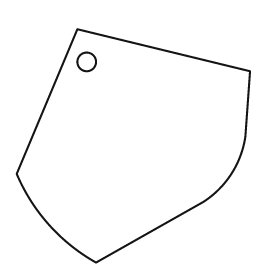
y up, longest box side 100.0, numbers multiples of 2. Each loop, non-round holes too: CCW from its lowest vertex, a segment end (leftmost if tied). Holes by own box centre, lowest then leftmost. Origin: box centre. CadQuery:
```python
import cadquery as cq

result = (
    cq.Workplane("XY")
    .moveTo(-16.0, -50.0)
    .lineTo(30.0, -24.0)
    .threePointArc((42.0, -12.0), (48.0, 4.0))
    .lineTo(50.0, 32.0)
    .lineTo(-24.0, 50.0)
    .lineTo(-50.0, -12.0)
    .threePointArc((-36.0, -34.0), (-16.0, -50.0))
    .close()
    .moveTo(-20.0, 36.0)
    .circle(4.0)
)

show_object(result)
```